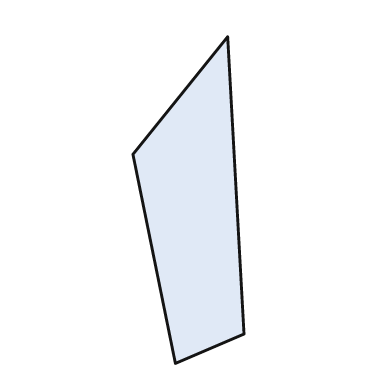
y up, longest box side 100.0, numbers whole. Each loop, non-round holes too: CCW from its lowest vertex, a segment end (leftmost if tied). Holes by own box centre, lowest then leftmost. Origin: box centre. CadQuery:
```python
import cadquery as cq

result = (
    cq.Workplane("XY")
    .moveTo(-4.0, -50.0)
    .lineTo(17.0, -41.0)
    .lineTo(12.0, 50.0)
    .lineTo(-17.0, 14.0)
    .close()
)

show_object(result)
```